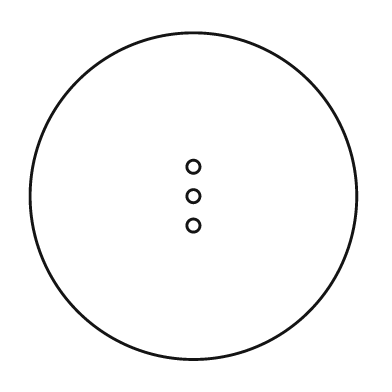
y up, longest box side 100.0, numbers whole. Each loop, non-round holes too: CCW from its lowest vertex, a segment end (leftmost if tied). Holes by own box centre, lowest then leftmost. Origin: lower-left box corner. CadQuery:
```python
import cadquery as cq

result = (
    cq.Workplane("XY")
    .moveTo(50.0, 50.0)
    .circle(50.0)
    .moveTo(50.0, 41.0)
    .circle(2.0)
    .moveTo(50.0, 50.0)
    .circle(2.0)
    .moveTo(50.0, 59.0)
    .circle(2.0)
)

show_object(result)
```